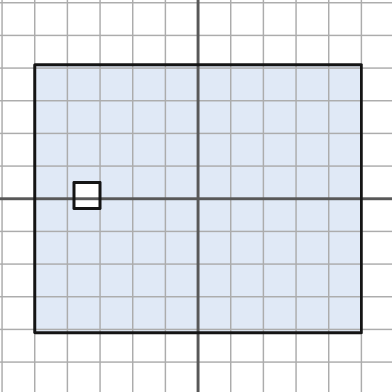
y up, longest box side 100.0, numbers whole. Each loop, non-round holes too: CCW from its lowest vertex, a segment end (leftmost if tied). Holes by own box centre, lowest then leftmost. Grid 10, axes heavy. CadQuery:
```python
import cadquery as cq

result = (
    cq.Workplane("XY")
    .moveTo(-50.0, -41.0)
    .lineTo(50.0, -41.0)
    .lineTo(50.0, 41.0)
    .lineTo(-50.0, 41.0)
    .close()
    .moveTo(-38.0, -3.0)
    .lineTo(-30.0, -3.0)
    .lineTo(-30.0, 5.0)
    .lineTo(-38.0, 5.0)
    .close()
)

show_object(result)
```